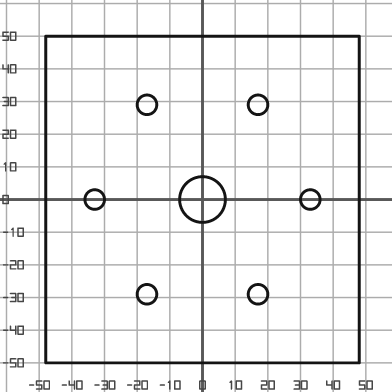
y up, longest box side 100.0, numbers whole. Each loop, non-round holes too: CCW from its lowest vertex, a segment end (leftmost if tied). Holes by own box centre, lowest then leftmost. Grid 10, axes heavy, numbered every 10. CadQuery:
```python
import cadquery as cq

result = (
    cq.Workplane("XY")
    .moveTo(-48.0, -50.0)
    .lineTo(48.0, -50.0)
    .lineTo(48.0, 50.0)
    .lineTo(-48.0, 50.0)
    .close()
    .moveTo(-17.0, -29.0)
    .circle(3.0)
    .moveTo(17.0, -29.0)
    .circle(3.0)
    .moveTo(-33.0, 0.0)
    .circle(3.0)
    .moveTo(0.0, 0.0)
    .circle(7.0)
    .moveTo(33.0, 0.0)
    .circle(3.0)
    .moveTo(-17.0, 29.0)
    .circle(3.0)
    .moveTo(17.0, 29.0)
    .circle(3.0)
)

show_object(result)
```